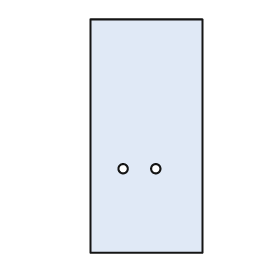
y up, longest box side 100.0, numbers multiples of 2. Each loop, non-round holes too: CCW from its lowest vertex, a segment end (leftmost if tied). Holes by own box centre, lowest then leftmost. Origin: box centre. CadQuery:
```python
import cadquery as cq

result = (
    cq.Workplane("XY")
    .moveTo(-24.0, -50.0)
    .lineTo(24.0, -50.0)
    .lineTo(24.0, 50.0)
    .lineTo(-24.0, 50.0)
    .close()
    .moveTo(-10.0, -14.0)
    .circle(2.0)
    .moveTo(4.0, -14.0)
    .circle(2.0)
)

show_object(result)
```